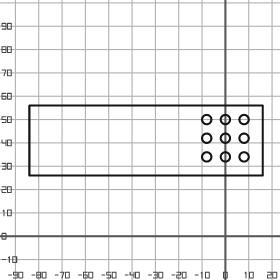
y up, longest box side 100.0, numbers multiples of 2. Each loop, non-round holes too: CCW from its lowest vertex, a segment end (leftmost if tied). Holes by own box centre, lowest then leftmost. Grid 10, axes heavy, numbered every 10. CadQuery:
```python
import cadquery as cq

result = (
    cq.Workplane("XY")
    .moveTo(-84.0, 26.0)
    .lineTo(16.0, 26.0)
    .lineTo(16.0, 56.0)
    .lineTo(-84.0, 56.0)
    .close()
    .moveTo(-8.0, 34.0)
    .circle(2.0)
    .moveTo(0.0, 34.0)
    .circle(2.0)
    .moveTo(8.0, 34.0)
    .circle(2.0)
    .moveTo(-8.0, 42.0)
    .circle(2.0)
    .moveTo(0.0, 42.0)
    .circle(2.0)
    .moveTo(8.0, 42.0)
    .circle(2.0)
    .moveTo(-8.0, 50.0)
    .circle(2.0)
    .moveTo(0.0, 50.0)
    .circle(2.0)
    .moveTo(8.0, 50.0)
    .circle(2.0)
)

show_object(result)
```